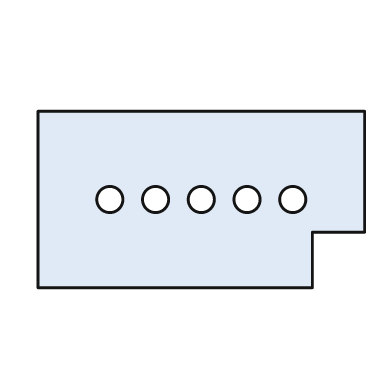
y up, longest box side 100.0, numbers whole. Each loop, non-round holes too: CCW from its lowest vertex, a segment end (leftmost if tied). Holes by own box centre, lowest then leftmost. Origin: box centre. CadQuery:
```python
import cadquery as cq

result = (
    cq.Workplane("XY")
    .moveTo(-50.0, -27.0)
    .lineTo(34.0, -27.0)
    .lineTo(34.0, -10.0)
    .lineTo(50.0, -10.0)
    .lineTo(50.0, 27.0)
    .lineTo(-50.0, 27.0)
    .close()
    .moveTo(-28.0, 0.0)
    .circle(4.0)
    .moveTo(-14.0, 0.0)
    .circle(4.0)
    .moveTo(0.0, 0.0)
    .circle(4.0)
    .moveTo(14.0, 0.0)
    .circle(4.0)
    .moveTo(28.0, 0.0)
    .circle(4.0)
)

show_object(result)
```